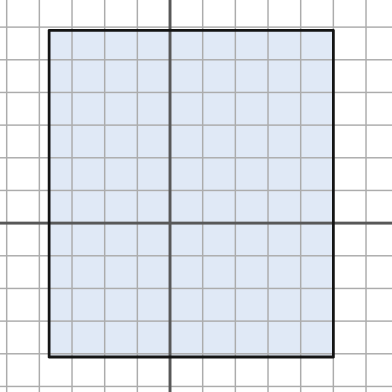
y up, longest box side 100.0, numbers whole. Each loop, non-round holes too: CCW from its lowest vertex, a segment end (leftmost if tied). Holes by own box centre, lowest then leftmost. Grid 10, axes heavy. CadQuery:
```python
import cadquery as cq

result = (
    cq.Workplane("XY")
    .moveTo(-37.0, -41.0)
    .lineTo(50.0, -41.0)
    .lineTo(50.0, 59.0)
    .lineTo(-37.0, 59.0)
    .close()
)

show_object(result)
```